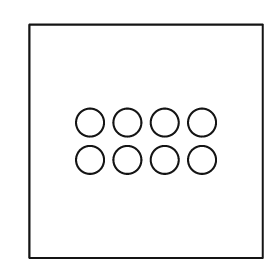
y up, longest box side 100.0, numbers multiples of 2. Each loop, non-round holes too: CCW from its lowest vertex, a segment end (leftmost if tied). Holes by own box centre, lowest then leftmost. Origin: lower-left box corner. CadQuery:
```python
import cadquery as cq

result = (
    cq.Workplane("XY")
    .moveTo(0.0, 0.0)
    .lineTo(100.0, 0.0)
    .lineTo(100.0, 100.0)
    .lineTo(0.0, 100.0)
    .close()
    .moveTo(26.0, 42.0)
    .circle(6.0)
    .moveTo(42.0, 42.0)
    .circle(6.0)
    .moveTo(58.0, 42.0)
    .circle(6.0)
    .moveTo(74.0, 42.0)
    .circle(6.0)
    .moveTo(26.0, 58.0)
    .circle(6.0)
    .moveTo(42.0, 58.0)
    .circle(6.0)
    .moveTo(58.0, 58.0)
    .circle(6.0)
    .moveTo(74.0, 58.0)
    .circle(6.0)
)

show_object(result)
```